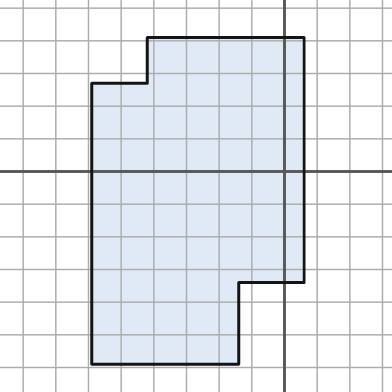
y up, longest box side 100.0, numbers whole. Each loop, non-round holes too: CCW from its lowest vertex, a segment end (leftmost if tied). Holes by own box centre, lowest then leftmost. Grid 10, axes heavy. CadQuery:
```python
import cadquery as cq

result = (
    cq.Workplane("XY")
    .moveTo(-59.0, -59.0)
    .lineTo(-14.0, -59.0)
    .lineTo(-14.0, -34.0)
    .lineTo(6.0, -34.0)
    .lineTo(6.0, 41.0)
    .lineTo(-42.0, 41.0)
    .lineTo(-42.0, 27.0)
    .lineTo(-59.0, 27.0)
    .close()
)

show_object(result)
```